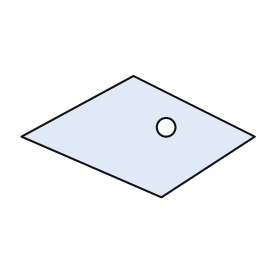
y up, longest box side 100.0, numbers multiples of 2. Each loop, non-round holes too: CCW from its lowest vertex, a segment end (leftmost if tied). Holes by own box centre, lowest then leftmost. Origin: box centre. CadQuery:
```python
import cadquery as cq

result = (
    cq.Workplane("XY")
    .moveTo(10.0, -26.0)
    .lineTo(50.0, 0.0)
    .lineTo(-2.0, 26.0)
    .lineTo(-50.0, 0.0)
    .close()
    .moveTo(12.0, 4.0)
    .circle(4.0)
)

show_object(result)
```